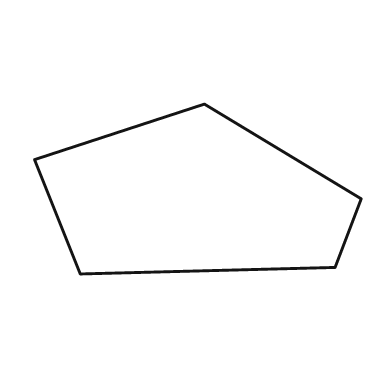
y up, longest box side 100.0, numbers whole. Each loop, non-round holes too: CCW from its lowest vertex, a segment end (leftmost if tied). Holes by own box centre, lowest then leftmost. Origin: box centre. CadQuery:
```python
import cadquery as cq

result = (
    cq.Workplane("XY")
    .moveTo(-36.0, -26.0)
    .lineTo(42.0, -24.0)
    .lineTo(50.0, -3.0)
    .lineTo(2.0, 26.0)
    .lineTo(-50.0, 9.0)
    .close()
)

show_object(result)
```